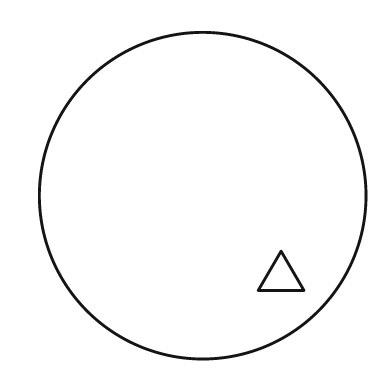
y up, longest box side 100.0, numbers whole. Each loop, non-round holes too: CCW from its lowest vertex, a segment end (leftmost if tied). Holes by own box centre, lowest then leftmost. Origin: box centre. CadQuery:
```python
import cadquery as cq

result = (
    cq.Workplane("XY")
    .moveTo(0.0, 0.0)
    .circle(50.0)
    .moveTo(17.0, -29.0)
    .lineTo(31.0, -29.0)
    .lineTo(24.0, -17.0)
    .close()
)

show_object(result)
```